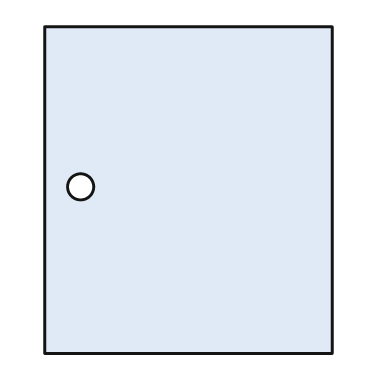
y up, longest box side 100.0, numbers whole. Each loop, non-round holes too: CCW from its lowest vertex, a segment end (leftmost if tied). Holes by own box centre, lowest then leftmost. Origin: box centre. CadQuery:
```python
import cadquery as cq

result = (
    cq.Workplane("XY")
    .moveTo(-44.0, -50.0)
    .lineTo(44.0, -50.0)
    .lineTo(44.0, 50.0)
    .lineTo(-44.0, 50.0)
    .close()
    .moveTo(-33.0, 1.0)
    .circle(4.0)
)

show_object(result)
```